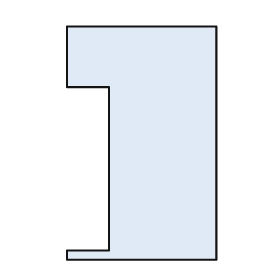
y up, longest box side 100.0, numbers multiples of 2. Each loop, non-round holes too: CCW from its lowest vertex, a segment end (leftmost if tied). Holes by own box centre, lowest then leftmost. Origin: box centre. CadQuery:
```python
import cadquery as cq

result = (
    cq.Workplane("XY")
    .moveTo(-32.0, -50.0)
    .lineTo(32.0, -50.0)
    .lineTo(32.0, 50.0)
    .lineTo(-32.0, 50.0)
    .lineTo(-32.0, 24.0)
    .lineTo(-14.0, 24.0)
    .lineTo(-14.0, -46.0)
    .lineTo(-32.0, -46.0)
    .close()
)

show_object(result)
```